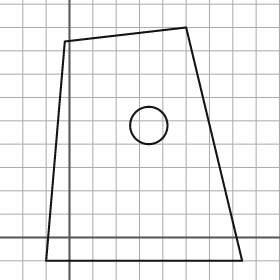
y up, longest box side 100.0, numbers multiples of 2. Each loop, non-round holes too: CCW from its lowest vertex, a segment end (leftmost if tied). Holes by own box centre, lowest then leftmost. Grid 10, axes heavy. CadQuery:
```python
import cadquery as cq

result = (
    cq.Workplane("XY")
    .moveTo(-10.0, -10.0)
    .lineTo(74.0, -10.0)
    .lineTo(50.0, 90.0)
    .lineTo(-2.0, 84.0)
    .close()
    .moveTo(34.0, 48.0)
    .circle(8.0)
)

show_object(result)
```